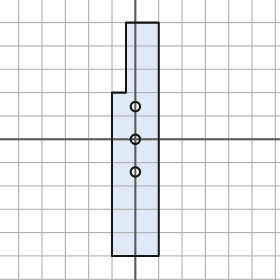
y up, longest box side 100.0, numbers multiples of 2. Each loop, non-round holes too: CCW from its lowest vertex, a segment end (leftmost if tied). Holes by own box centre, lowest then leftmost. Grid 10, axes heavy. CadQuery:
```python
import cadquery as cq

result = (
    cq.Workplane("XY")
    .moveTo(-10.0, -50.0)
    .lineTo(10.0, -50.0)
    .lineTo(10.0, 50.0)
    .lineTo(-4.0, 50.0)
    .lineTo(-4.0, 20.0)
    .lineTo(-10.0, 20.0)
    .close()
    .moveTo(0.0, -14.0)
    .circle(2.0)
    .moveTo(0.0, 0.0)
    .circle(2.0)
    .moveTo(0.0, 14.0)
    .circle(2.0)
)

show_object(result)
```